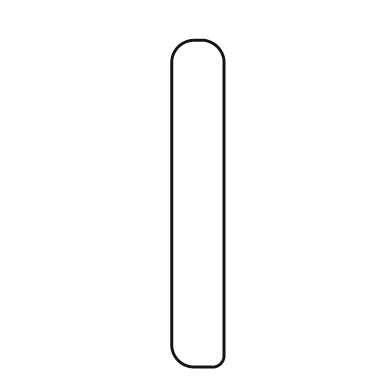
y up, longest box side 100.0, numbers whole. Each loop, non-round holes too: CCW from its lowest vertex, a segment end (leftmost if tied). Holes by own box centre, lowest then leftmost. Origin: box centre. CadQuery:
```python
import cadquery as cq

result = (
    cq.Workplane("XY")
    .moveTo(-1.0, -50.0)
    .lineTo(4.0, -50.0)
    .threePointArc((7.0, -49.0), (8.0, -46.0))
    .lineTo(8.0, 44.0)
    .threePointArc((6.0, 48.0), (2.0, 50.0))
    .lineTo(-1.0, 50.0)
    .threePointArc((-6.0, 48.0), (-8.0, 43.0))
    .lineTo(-8.0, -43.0)
    .threePointArc((-6.0, -48.0), (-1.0, -50.0))
    .close()
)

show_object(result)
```